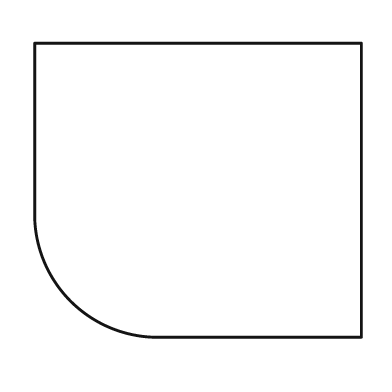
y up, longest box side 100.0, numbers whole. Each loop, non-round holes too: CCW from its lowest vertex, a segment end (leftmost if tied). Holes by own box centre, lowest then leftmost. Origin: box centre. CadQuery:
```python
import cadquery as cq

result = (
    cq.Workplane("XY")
    .moveTo(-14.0, -45.0)
    .lineTo(50.0, -45.0)
    .lineTo(50.0, 45.0)
    .lineTo(-50.0, 45.0)
    .lineTo(-50.0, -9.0)
    .threePointArc((-39.0, -34.0), (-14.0, -45.0))
    .close()
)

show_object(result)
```